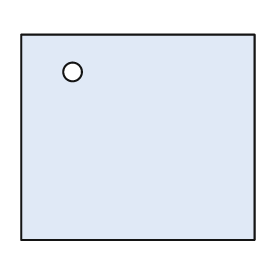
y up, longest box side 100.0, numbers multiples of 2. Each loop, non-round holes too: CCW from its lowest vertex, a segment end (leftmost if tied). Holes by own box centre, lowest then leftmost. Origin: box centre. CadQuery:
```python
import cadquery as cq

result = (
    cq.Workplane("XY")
    .moveTo(-50.0, -44.0)
    .lineTo(50.0, -44.0)
    .lineTo(50.0, 44.0)
    .lineTo(-50.0, 44.0)
    .close()
    .moveTo(-28.0, 28.0)
    .circle(4.0)
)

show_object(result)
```